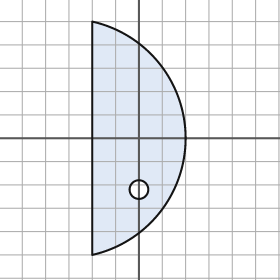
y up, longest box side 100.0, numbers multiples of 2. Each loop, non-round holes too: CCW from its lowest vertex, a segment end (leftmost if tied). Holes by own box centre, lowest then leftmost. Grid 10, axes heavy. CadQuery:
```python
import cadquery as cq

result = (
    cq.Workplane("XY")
    .moveTo(-20.0, -50.0)
    .threePointArc((20.0, 0.0), (-20.0, 50.0))
    .close()
    .moveTo(0.0, -22.0)
    .circle(4.0)
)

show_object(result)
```